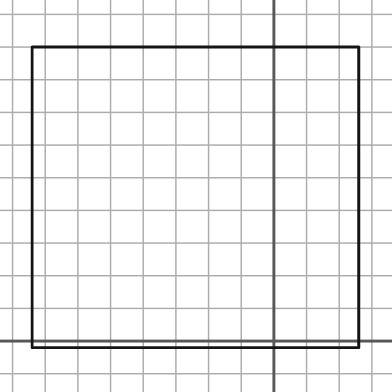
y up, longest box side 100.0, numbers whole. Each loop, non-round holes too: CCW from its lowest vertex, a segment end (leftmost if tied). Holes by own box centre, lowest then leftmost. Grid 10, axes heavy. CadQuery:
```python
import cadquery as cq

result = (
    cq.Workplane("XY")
    .moveTo(-74.0, -2.0)
    .lineTo(26.0, -2.0)
    .lineTo(26.0, 90.0)
    .lineTo(-74.0, 90.0)
    .close()
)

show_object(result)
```